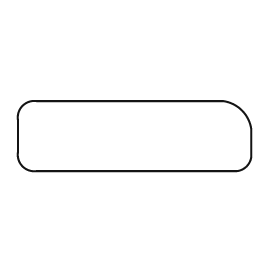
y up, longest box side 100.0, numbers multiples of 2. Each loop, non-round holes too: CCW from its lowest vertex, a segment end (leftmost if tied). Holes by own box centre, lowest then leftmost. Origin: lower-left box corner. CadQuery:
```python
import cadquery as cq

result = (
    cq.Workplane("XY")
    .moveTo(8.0, 0.0)
    .lineTo(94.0, 0.0)
    .threePointArc((98.0, 2.0), (100.0, 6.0))
    .lineTo(100.0, 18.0)
    .threePointArc((96.0, 26.0), (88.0, 30.0))
    .lineTo(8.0, 30.0)
    .threePointArc((2.0, 28.0), (0.0, 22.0))
    .lineTo(0.0, 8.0)
    .threePointArc((2.0, 2.0), (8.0, 0.0))
    .close()
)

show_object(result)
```